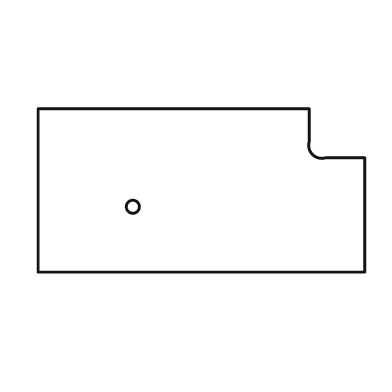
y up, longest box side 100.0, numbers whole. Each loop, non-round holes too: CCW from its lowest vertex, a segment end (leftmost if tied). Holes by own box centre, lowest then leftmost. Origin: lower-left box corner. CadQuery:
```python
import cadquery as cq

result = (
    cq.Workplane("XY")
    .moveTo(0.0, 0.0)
    .lineTo(100.0, 0.0)
    .lineTo(100.0, 35.0)
    .lineTo(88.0, 35.0)
    .threePointArc((84.0, 36.0), (83.0, 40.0))
    .lineTo(83.0, 50.0)
    .lineTo(0.0, 50.0)
    .close()
    .moveTo(29.0, 20.0)
    .circle(2.0)
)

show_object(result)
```